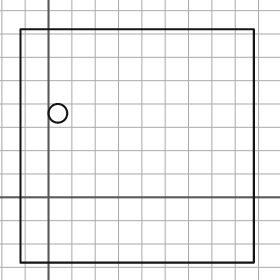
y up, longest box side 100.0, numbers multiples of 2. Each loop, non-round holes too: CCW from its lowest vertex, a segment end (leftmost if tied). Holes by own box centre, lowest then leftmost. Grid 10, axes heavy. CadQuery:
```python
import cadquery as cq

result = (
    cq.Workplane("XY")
    .moveTo(-12.0, -28.0)
    .lineTo(88.0, -28.0)
    .lineTo(88.0, 72.0)
    .lineTo(-12.0, 72.0)
    .close()
    .moveTo(4.0, 36.0)
    .circle(4.0)
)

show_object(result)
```